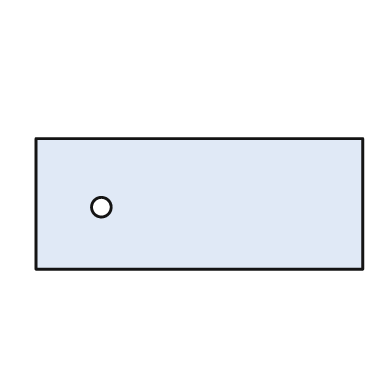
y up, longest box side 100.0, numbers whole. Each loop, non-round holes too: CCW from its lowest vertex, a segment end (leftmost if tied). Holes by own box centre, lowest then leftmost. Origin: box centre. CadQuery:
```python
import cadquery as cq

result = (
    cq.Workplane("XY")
    .moveTo(-50.0, -20.0)
    .lineTo(50.0, -20.0)
    .lineTo(50.0, 20.0)
    .lineTo(-50.0, 20.0)
    .close()
    .moveTo(-30.0, -1.0)
    .circle(3.0)
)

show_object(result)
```